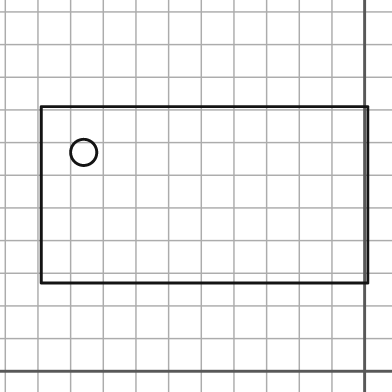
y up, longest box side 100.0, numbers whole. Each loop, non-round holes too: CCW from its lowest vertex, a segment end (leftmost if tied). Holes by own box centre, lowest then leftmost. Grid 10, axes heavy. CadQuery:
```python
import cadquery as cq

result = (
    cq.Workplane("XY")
    .moveTo(-99.0, 27.0)
    .lineTo(1.0, 27.0)
    .lineTo(1.0, 81.0)
    .lineTo(-99.0, 81.0)
    .close()
    .moveTo(-86.0, 67.0)
    .circle(4.0)
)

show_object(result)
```